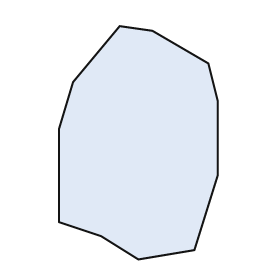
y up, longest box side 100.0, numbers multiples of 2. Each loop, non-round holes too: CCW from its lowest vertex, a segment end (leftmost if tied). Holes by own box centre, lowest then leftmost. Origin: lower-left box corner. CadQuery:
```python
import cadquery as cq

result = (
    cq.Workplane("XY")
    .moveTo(34.0, 0.0)
    .lineTo(58.0, 4.0)
    .lineTo(68.0, 36.0)
    .lineTo(68.0, 68.0)
    .lineTo(64.0, 84.0)
    .lineTo(40.0, 98.0)
    .lineTo(26.0, 100.0)
    .lineTo(6.0, 76.0)
    .lineTo(0.0, 56.0)
    .lineTo(0.0, 16.0)
    .lineTo(18.0, 10.0)
    .close()
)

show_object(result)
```